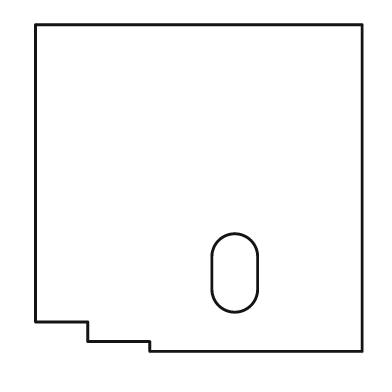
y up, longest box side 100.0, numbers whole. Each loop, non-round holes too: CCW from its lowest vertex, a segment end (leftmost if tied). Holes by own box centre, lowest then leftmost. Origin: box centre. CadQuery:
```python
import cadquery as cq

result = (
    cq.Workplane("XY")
    .moveTo(-15.0, -50.0)
    .lineTo(50.0, -50.0)
    .lineTo(50.0, 50.0)
    .lineTo(-50.0, 50.0)
    .lineTo(-50.0, -41.0)
    .lineTo(-34.0, -41.0)
    .lineTo(-34.0, -47.0)
    .lineTo(-15.0, -47.0)
    .close()
    .moveTo(4.0, -31.0)
    .threePointArc((11.0, -38.0), (18.0, -31.0))
    .lineTo(18.0, -21.0)
    .threePointArc((11.0, -14.0), (4.0, -21.0))
    .close()
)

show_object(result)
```